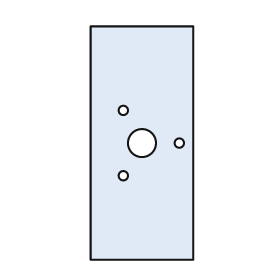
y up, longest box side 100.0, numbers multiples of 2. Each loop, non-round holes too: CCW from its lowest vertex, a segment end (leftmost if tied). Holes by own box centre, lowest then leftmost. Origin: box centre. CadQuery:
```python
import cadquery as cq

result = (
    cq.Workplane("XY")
    .moveTo(-22.0, -50.0)
    .lineTo(22.0, -50.0)
    .lineTo(22.0, 50.0)
    .lineTo(-22.0, 50.0)
    .close()
    .moveTo(-8.0, -14.0)
    .circle(2.0)
    .moveTo(0.0, 0.0)
    .circle(6.0)
    .moveTo(16.0, 0.0)
    .circle(2.0)
    .moveTo(-8.0, 14.0)
    .circle(2.0)
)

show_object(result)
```